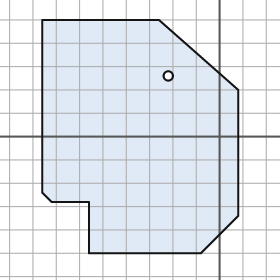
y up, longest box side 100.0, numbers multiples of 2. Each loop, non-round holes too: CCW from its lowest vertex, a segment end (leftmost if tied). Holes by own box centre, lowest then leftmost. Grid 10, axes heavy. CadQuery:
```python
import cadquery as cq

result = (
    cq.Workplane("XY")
    .moveTo(-56.0, -50.0)
    .lineTo(-8.0, -50.0)
    .lineTo(8.0, -34.0)
    .lineTo(8.0, 20.0)
    .lineTo(-26.0, 50.0)
    .lineTo(-76.0, 50.0)
    .lineTo(-76.0, -24.0)
    .lineTo(-72.0, -28.0)
    .lineTo(-56.0, -28.0)
    .close()
    .moveTo(-22.0, 26.0)
    .circle(2.0)
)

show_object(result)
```